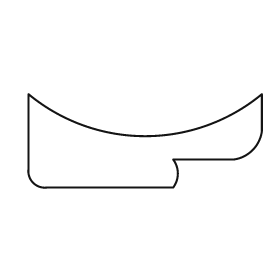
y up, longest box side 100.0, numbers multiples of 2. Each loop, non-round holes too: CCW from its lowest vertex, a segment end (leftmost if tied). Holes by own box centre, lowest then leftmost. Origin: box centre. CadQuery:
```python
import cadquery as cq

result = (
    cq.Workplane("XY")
    .moveTo(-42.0, -20.0)
    .lineTo(12.0, -20.0)
    .threePointArc((14.0, -14.0), (12.0, -8.0))
    .lineTo(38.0, -8.0)
    .threePointArc((46.0, -4.0), (50.0, 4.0))
    .lineTo(50.0, 20.0)
    .threePointArc((0.0, 2.0), (-50.0, 20.0))
    .lineTo(-50.0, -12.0)
    .threePointArc((-48.0, -18.0), (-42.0, -20.0))
    .close()
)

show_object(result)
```